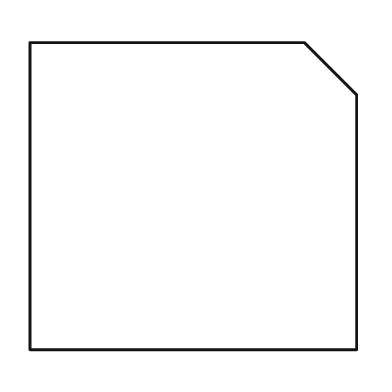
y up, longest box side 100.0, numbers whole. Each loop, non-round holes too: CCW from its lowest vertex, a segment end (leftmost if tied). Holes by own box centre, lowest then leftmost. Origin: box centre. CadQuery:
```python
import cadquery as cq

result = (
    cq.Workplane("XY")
    .moveTo(-50.0, -47.0)
    .lineTo(50.0, -47.0)
    .lineTo(50.0, 31.0)
    .lineTo(34.0, 47.0)
    .lineTo(-50.0, 47.0)
    .close()
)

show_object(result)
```